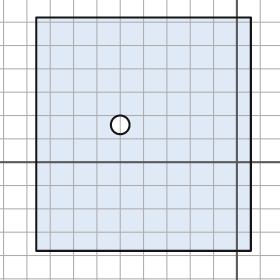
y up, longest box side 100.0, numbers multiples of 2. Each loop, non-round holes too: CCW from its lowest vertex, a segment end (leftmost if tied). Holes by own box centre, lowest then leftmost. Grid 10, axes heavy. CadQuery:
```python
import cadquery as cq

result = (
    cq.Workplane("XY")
    .moveTo(-86.0, -38.0)
    .lineTo(6.0, -38.0)
    .lineTo(6.0, 62.0)
    .lineTo(-86.0, 62.0)
    .close()
    .moveTo(-50.0, 16.0)
    .circle(4.0)
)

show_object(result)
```